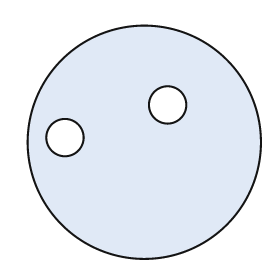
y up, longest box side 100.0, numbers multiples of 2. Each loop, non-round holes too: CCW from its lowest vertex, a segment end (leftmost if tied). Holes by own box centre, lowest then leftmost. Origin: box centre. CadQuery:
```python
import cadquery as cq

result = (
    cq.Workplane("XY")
    .moveTo(0.0, 0.0)
    .circle(50.0)
    .moveTo(-34.0, 2.0)
    .circle(8.0)
    .moveTo(10.0, 16.0)
    .circle(8.0)
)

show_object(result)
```